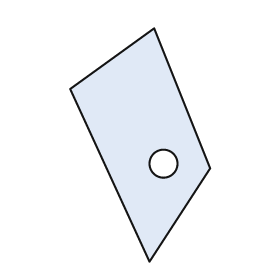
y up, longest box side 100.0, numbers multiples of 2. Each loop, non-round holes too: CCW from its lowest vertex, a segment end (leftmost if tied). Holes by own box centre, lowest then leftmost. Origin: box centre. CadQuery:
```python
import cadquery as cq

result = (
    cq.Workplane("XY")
    .moveTo(4.0, -50.0)
    .lineTo(30.0, -10.0)
    .lineTo(6.0, 50.0)
    .lineTo(-30.0, 24.0)
    .close()
    .moveTo(10.0, -8.0)
    .circle(6.0)
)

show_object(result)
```